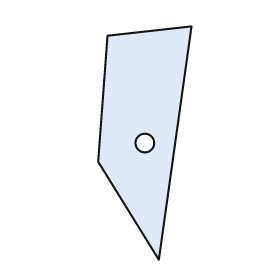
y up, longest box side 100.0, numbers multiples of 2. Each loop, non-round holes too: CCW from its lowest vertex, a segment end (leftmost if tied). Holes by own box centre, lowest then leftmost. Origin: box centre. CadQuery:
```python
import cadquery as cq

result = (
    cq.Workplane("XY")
    .moveTo(6.0, -50.0)
    .lineTo(20.0, 50.0)
    .lineTo(-16.0, 46.0)
    .lineTo(-20.0, -8.0)
    .close()
    .moveTo(0.0, 0.0)
    .circle(4.0)
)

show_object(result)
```